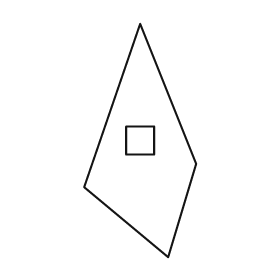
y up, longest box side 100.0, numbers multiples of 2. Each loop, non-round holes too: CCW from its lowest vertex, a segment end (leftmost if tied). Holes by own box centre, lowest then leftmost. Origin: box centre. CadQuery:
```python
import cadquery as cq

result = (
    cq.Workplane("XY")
    .moveTo(12.0, -50.0)
    .lineTo(24.0, -10.0)
    .lineTo(0.0, 50.0)
    .lineTo(-24.0, -20.0)
    .close()
    .moveTo(-6.0, -6.0)
    .lineTo(6.0, -6.0)
    .lineTo(6.0, 6.0)
    .lineTo(-6.0, 6.0)
    .close()
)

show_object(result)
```